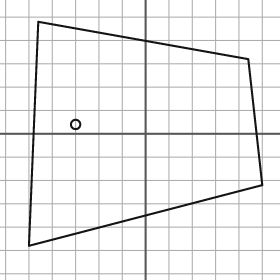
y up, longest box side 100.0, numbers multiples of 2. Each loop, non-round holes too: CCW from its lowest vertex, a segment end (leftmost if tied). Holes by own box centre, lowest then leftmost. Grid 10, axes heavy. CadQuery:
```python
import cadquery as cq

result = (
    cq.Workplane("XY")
    .moveTo(-50.0, -48.0)
    .lineTo(50.0, -22.0)
    .lineTo(44.0, 32.0)
    .lineTo(-46.0, 48.0)
    .close()
    .moveTo(-30.0, 4.0)
    .circle(2.0)
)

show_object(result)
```